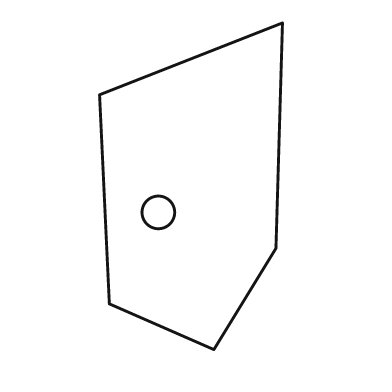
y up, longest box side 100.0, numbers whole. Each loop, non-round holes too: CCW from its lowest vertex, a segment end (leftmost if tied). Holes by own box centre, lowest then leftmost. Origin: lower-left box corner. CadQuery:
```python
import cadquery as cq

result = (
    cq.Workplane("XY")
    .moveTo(35.0, 0.0)
    .lineTo(54.0, 31.0)
    .lineTo(56.0, 100.0)
    .lineTo(0.0, 78.0)
    .lineTo(3.0, 14.0)
    .close()
    .moveTo(18.0, 42.0)
    .circle(5.0)
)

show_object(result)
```